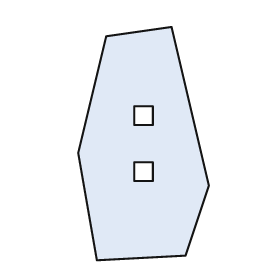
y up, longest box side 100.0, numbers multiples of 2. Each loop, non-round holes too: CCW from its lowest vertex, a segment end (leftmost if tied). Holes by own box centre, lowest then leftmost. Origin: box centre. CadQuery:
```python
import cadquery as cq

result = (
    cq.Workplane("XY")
    .moveTo(-20.0, -50.0)
    .lineTo(18.0, -48.0)
    .lineTo(28.0, -18.0)
    .lineTo(12.0, 50.0)
    .lineTo(-16.0, 46.0)
    .lineTo(-28.0, -4.0)
    .close()
    .moveTo(-4.0, -16.0)
    .lineTo(4.0, -16.0)
    .lineTo(4.0, -8.0)
    .lineTo(-4.0, -8.0)
    .close()
    .moveTo(-4.0, 8.0)
    .lineTo(4.0, 8.0)
    .lineTo(4.0, 16.0)
    .lineTo(-4.0, 16.0)
    .close()
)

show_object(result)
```